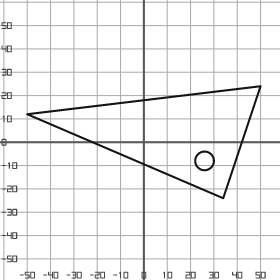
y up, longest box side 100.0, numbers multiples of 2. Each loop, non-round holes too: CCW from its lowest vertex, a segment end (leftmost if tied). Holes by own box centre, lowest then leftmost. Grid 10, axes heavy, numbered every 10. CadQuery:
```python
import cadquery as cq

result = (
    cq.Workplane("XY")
    .moveTo(34.0, -24.0)
    .lineTo(50.0, 24.0)
    .lineTo(-50.0, 12.0)
    .close()
    .moveTo(26.0, -8.0)
    .circle(4.0)
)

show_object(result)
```